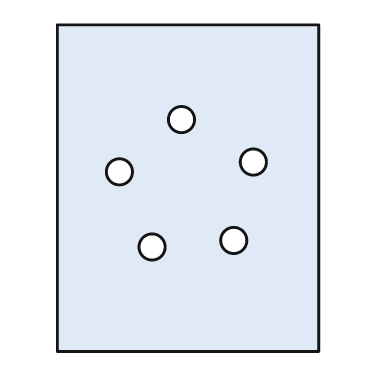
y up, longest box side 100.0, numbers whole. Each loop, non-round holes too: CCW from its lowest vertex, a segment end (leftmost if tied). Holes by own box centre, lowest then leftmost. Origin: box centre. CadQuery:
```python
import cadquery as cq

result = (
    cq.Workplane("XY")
    .moveTo(-40.0, -50.0)
    .lineTo(40.0, -50.0)
    .lineTo(40.0, 50.0)
    .lineTo(-40.0, 50.0)
    .close()
    .moveTo(-11.0, -18.0)
    .circle(4.0)
    .moveTo(14.0, -16.0)
    .circle(4.0)
    .moveTo(-21.0, 5.0)
    .circle(4.0)
    .moveTo(20.0, 8.0)
    .circle(4.0)
    .moveTo(-2.0, 21.0)
    .circle(4.0)
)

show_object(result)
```